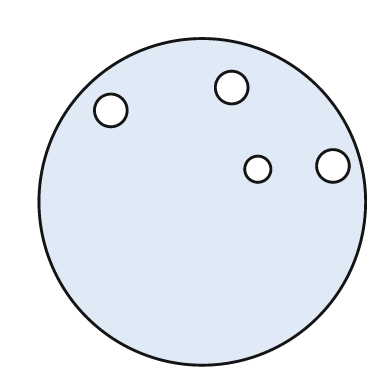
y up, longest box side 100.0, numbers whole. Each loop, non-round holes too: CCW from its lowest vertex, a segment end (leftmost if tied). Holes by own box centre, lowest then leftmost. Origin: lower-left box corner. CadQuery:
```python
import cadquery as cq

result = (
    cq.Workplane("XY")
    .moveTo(50.0, 50.0)
    .circle(50.0)
    .moveTo(67.0, 60.0)
    .circle(4.0)
    .moveTo(90.0, 61.0)
    .circle(5.0)
    .moveTo(22.0, 78.0)
    .circle(5.0)
    .moveTo(59.0, 85.0)
    .circle(5.0)
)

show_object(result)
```